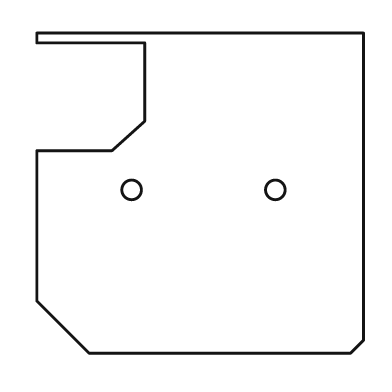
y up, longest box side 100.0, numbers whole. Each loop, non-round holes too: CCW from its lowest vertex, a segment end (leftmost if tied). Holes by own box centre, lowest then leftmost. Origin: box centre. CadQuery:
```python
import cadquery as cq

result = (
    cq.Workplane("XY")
    .moveTo(-34.0, -49.0)
    .lineTo(46.0, -49.0)
    .lineTo(50.0, -45.0)
    .lineTo(50.0, 49.0)
    .lineTo(-50.0, 49.0)
    .lineTo(-50.0, 46.0)
    .lineTo(-17.0, 46.0)
    .lineTo(-17.0, 22.0)
    .lineTo(-27.0, 13.0)
    .lineTo(-50.0, 13.0)
    .lineTo(-50.0, -33.0)
    .close()
    .moveTo(-21.0, 1.0)
    .circle(3.0)
    .moveTo(23.0, 1.0)
    .circle(3.0)
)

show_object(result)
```